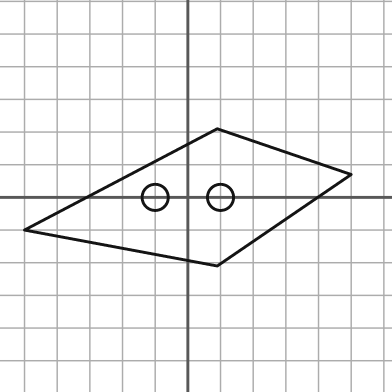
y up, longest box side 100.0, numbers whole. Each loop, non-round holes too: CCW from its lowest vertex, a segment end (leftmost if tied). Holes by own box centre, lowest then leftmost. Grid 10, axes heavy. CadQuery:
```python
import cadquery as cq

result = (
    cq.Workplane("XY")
    .moveTo(9.0, -21.0)
    .lineTo(50.0, 7.0)
    .lineTo(9.0, 21.0)
    .lineTo(-50.0, -10.0)
    .close()
    .moveTo(-10.0, 0.0)
    .circle(4.0)
    .moveTo(10.0, 0.0)
    .circle(4.0)
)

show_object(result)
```